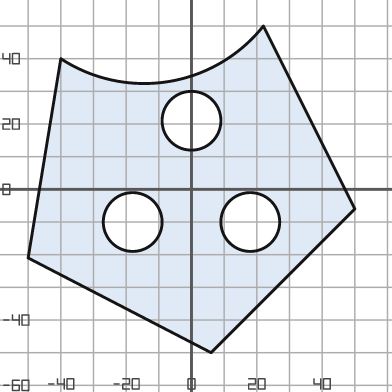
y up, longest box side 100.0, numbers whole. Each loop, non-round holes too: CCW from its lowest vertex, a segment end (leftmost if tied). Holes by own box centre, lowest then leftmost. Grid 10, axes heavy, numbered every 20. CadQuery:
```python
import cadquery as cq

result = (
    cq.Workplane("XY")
    .moveTo(6.0, -50.0)
    .lineTo(50.0, -6.0)
    .lineTo(22.0, 50.0)
    .threePointArc((-7.0, 33.0), (-40.0, 40.0))
    .lineTo(-50.0, -21.0)
    .close()
    .moveTo(-18.0, -10.0)
    .circle(9.0)
    .moveTo(18.0, -10.0)
    .circle(9.0)
    .moveTo(0.0, 21.0)
    .circle(9.0)
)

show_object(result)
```